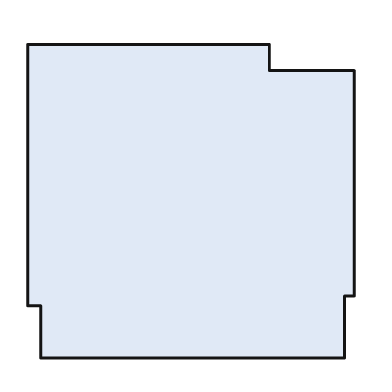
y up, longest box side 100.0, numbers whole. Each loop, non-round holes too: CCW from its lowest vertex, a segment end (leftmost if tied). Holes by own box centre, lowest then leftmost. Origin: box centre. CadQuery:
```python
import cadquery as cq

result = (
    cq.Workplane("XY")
    .moveTo(-46.0, -48.0)
    .lineTo(47.0, -48.0)
    .lineTo(47.0, -29.0)
    .lineTo(50.0, -29.0)
    .lineTo(50.0, 40.0)
    .lineTo(24.0, 40.0)
    .lineTo(24.0, 48.0)
    .lineTo(-50.0, 48.0)
    .lineTo(-50.0, -32.0)
    .lineTo(-46.0, -32.0)
    .close()
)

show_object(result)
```